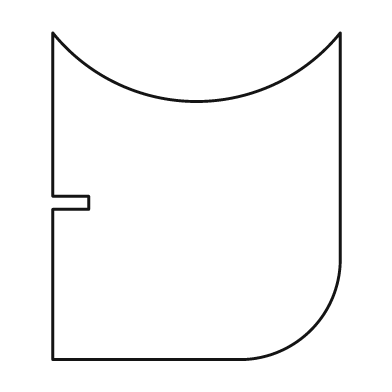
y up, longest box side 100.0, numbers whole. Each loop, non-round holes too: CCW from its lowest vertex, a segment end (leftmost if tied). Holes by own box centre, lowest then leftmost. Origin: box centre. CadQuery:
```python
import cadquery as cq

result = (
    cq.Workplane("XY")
    .moveTo(-44.0, -50.0)
    .lineTo(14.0, -50.0)
    .threePointArc((35.0, -41.0), (44.0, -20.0))
    .lineTo(44.0, 50.0)
    .threePointArc((0.0, 29.0), (-44.0, 50.0))
    .lineTo(-44.0, 0.0)
    .lineTo(-33.0, 0.0)
    .lineTo(-33.0, -4.0)
    .lineTo(-44.0, -4.0)
    .close()
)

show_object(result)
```